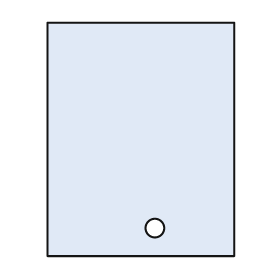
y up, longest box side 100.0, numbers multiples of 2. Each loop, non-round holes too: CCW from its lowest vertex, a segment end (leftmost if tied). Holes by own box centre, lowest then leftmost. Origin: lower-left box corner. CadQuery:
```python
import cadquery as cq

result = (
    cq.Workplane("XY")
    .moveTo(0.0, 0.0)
    .lineTo(80.0, 0.0)
    .lineTo(80.0, 100.0)
    .lineTo(0.0, 100.0)
    .close()
    .moveTo(46.0, 12.0)
    .circle(4.0)
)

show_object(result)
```